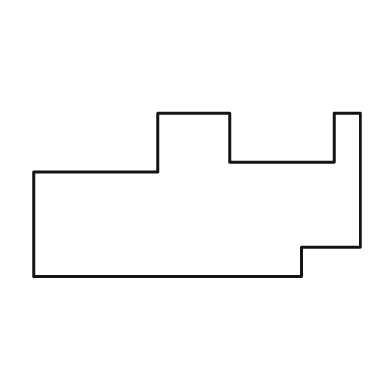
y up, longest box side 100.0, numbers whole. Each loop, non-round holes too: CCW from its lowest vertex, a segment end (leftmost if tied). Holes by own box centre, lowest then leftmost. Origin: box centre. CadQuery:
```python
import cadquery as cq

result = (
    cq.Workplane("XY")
    .moveTo(-50.0, -25.0)
    .lineTo(32.0, -25.0)
    .lineTo(32.0, -16.0)
    .lineTo(50.0, -16.0)
    .lineTo(50.0, 25.0)
    .lineTo(42.0, 25.0)
    .lineTo(42.0, 10.0)
    .lineTo(10.0, 10.0)
    .lineTo(10.0, 25.0)
    .lineTo(-12.0, 25.0)
    .lineTo(-12.0, 7.0)
    .lineTo(-50.0, 7.0)
    .close()
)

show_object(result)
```